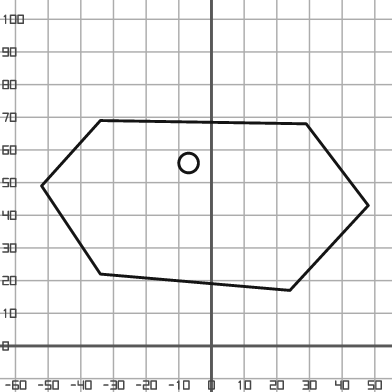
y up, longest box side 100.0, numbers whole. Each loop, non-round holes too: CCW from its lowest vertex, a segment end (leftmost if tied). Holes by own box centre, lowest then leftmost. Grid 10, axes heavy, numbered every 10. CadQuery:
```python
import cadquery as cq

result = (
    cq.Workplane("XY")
    .moveTo(24.0, 17.0)
    .lineTo(48.0, 43.0)
    .lineTo(29.0, 68.0)
    .lineTo(-34.0, 69.0)
    .lineTo(-52.0, 49.0)
    .lineTo(-34.0, 22.0)
    .close()
    .moveTo(-7.0, 56.0)
    .circle(3.0)
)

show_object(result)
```